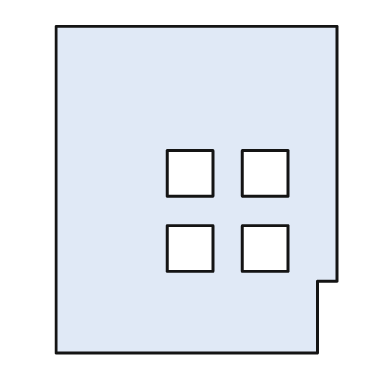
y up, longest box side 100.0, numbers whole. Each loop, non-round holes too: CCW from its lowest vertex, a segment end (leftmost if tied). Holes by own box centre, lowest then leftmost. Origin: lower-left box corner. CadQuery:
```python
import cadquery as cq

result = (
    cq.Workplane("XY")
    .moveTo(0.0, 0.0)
    .lineTo(80.0, 0.0)
    .lineTo(80.0, 22.0)
    .lineTo(86.0, 22.0)
    .lineTo(86.0, 100.0)
    .lineTo(0.0, 100.0)
    .close()
    .moveTo(34.0, 25.0)
    .lineTo(48.0, 25.0)
    .lineTo(48.0, 39.0)
    .lineTo(34.0, 39.0)
    .close()
    .moveTo(57.0, 25.0)
    .lineTo(71.0, 25.0)
    .lineTo(71.0, 39.0)
    .lineTo(57.0, 39.0)
    .close()
    .moveTo(34.0, 48.0)
    .lineTo(48.0, 48.0)
    .lineTo(48.0, 62.0)
    .lineTo(34.0, 62.0)
    .close()
    .moveTo(57.0, 48.0)
    .lineTo(71.0, 48.0)
    .lineTo(71.0, 62.0)
    .lineTo(57.0, 62.0)
    .close()
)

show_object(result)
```